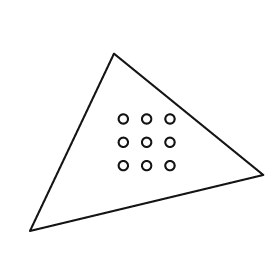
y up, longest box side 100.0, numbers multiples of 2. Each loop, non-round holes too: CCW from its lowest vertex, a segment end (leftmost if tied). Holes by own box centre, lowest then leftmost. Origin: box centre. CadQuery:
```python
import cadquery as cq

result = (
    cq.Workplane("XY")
    .moveTo(-50.0, -38.0)
    .lineTo(50.0, -14.0)
    .lineTo(-14.0, 38.0)
    .close()
    .moveTo(-10.0, -10.0)
    .circle(2.0)
    .moveTo(0.0, -10.0)
    .circle(2.0)
    .moveTo(10.0, -10.0)
    .circle(2.0)
    .moveTo(-10.0, 0.0)
    .circle(2.0)
    .moveTo(0.0, 0.0)
    .circle(2.0)
    .moveTo(10.0, 0.0)
    .circle(2.0)
    .moveTo(-10.0, 10.0)
    .circle(2.0)
    .moveTo(0.0, 10.0)
    .circle(2.0)
    .moveTo(10.0, 10.0)
    .circle(2.0)
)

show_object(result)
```